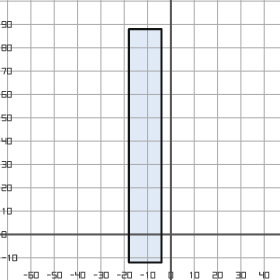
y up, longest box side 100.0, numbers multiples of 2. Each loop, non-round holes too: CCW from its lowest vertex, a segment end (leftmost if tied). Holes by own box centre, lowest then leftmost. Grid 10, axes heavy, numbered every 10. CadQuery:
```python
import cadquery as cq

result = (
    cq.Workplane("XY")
    .moveTo(-18.0, -12.0)
    .lineTo(-4.0, -12.0)
    .lineTo(-4.0, 88.0)
    .lineTo(-18.0, 88.0)
    .close()
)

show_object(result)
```